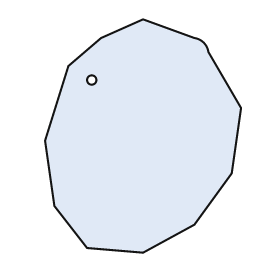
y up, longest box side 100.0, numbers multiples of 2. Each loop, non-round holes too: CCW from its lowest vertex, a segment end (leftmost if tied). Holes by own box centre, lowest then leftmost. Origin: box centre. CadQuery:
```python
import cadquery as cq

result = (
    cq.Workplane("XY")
    .moveTo(0.0, -50.0)
    .lineTo(22.0, -38.0)
    .lineTo(38.0, -16.0)
    .lineTo(42.0, 12.0)
    .lineTo(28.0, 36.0)
    .threePointArc((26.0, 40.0), (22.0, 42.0))
    .lineTo(0.0, 50.0)
    .lineTo(-18.0, 42.0)
    .lineTo(-32.0, 30.0)
    .lineTo(-42.0, -2.0)
    .lineTo(-38.0, -30.0)
    .lineTo(-24.0, -48.0)
    .close()
    .moveTo(-22.0, 24.0)
    .circle(2.0)
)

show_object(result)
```